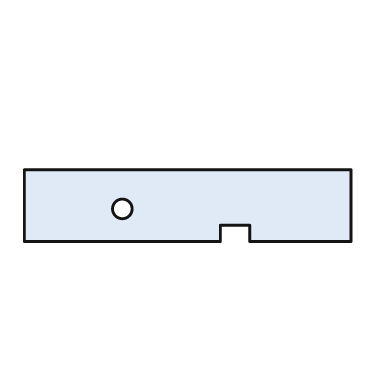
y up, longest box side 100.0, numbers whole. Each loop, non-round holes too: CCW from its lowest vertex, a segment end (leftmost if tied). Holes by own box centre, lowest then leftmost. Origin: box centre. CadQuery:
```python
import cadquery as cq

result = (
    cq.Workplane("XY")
    .moveTo(-50.0, -11.0)
    .lineTo(10.0, -11.0)
    .lineTo(10.0, -6.0)
    .lineTo(19.0, -6.0)
    .lineTo(19.0, -11.0)
    .lineTo(50.0, -11.0)
    .lineTo(50.0, 11.0)
    .lineTo(-50.0, 11.0)
    .close()
    .moveTo(-20.0, -1.0)
    .circle(3.0)
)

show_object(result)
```